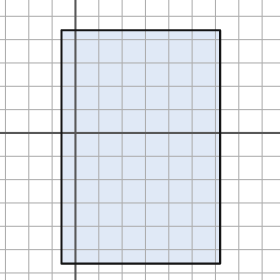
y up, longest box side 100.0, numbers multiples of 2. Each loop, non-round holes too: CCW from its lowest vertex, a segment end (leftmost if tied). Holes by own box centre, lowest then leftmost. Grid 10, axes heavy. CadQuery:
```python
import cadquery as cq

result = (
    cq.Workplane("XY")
    .moveTo(-6.0, -56.0)
    .lineTo(62.0, -56.0)
    .lineTo(62.0, 44.0)
    .lineTo(-6.0, 44.0)
    .close()
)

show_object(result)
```